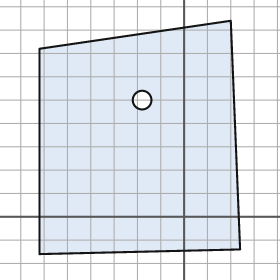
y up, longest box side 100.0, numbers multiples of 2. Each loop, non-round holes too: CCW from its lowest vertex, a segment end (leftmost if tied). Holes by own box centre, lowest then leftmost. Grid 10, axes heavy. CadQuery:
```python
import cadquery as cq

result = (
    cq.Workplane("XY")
    .moveTo(-62.0, -16.0)
    .lineTo(24.0, -14.0)
    .lineTo(20.0, 84.0)
    .lineTo(-62.0, 72.0)
    .close()
    .moveTo(-18.0, 50.0)
    .circle(4.0)
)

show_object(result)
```